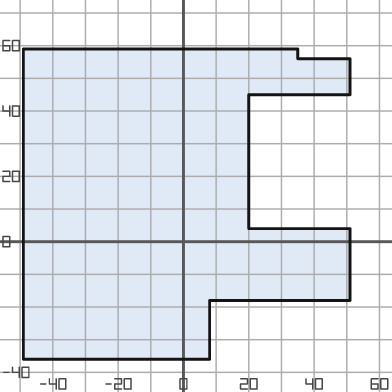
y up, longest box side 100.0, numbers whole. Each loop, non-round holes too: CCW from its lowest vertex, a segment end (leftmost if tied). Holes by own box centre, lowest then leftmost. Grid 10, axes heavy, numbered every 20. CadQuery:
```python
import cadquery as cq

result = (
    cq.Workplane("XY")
    .moveTo(-49.0, -36.0)
    .lineTo(8.0, -36.0)
    .lineTo(8.0, -18.0)
    .lineTo(51.0, -18.0)
    .lineTo(51.0, 4.0)
    .lineTo(20.0, 4.0)
    .lineTo(20.0, 45.0)
    .lineTo(51.0, 45.0)
    .lineTo(51.0, 56.0)
    .lineTo(35.0, 56.0)
    .lineTo(35.0, 59.0)
    .lineTo(-49.0, 59.0)
    .close()
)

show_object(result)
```